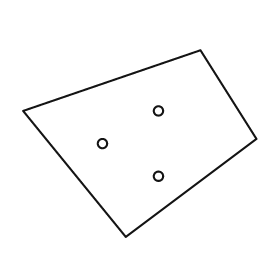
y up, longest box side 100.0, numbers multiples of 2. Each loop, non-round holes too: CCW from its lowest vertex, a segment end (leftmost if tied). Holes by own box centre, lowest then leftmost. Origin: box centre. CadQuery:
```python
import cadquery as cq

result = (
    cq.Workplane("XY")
    .moveTo(-6.0, -40.0)
    .lineTo(50.0, 2.0)
    .lineTo(26.0, 40.0)
    .lineTo(-50.0, 14.0)
    .close()
    .moveTo(8.0, -14.0)
    .circle(2.0)
    .moveTo(-16.0, 0.0)
    .circle(2.0)
    .moveTo(8.0, 14.0)
    .circle(2.0)
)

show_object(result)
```